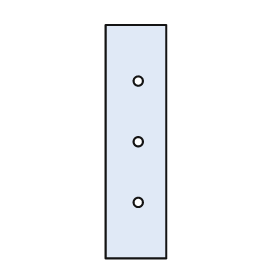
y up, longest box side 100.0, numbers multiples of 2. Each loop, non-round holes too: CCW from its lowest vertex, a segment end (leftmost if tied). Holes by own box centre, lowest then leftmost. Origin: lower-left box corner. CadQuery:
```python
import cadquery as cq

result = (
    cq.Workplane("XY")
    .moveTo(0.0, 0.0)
    .lineTo(26.0, 0.0)
    .lineTo(26.0, 100.0)
    .lineTo(0.0, 100.0)
    .close()
    .moveTo(14.0, 24.0)
    .circle(2.0)
    .moveTo(14.0, 50.0)
    .circle(2.0)
    .moveTo(14.0, 76.0)
    .circle(2.0)
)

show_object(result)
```